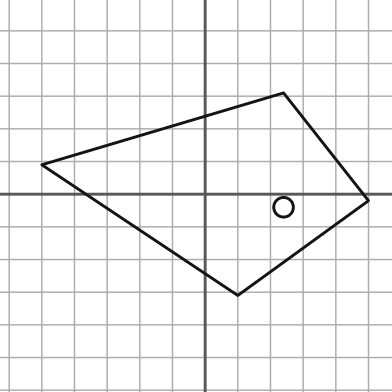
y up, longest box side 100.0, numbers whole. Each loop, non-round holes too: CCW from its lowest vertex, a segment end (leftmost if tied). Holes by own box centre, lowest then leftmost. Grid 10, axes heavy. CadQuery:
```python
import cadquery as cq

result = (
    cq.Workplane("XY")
    .moveTo(10.0, -31.0)
    .lineTo(50.0, -2.0)
    .lineTo(24.0, 31.0)
    .lineTo(-50.0, 9.0)
    .close()
    .moveTo(24.0, -4.0)
    .circle(3.0)
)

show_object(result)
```